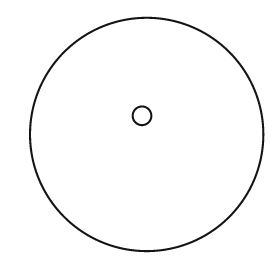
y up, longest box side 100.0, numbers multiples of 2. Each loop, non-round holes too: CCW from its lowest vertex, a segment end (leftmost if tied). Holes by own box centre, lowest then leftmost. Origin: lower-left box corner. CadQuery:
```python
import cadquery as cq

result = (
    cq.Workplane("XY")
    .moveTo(50.0, 50.0)
    .circle(50.0)
    .moveTo(48.0, 58.0)
    .circle(4.0)
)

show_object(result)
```